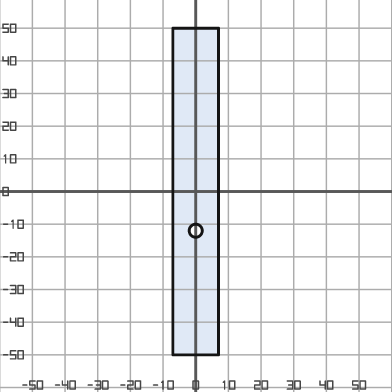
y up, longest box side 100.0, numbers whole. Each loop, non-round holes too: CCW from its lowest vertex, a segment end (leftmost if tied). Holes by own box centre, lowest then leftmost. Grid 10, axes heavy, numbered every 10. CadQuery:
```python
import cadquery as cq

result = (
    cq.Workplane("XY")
    .moveTo(-7.0, -50.0)
    .lineTo(7.0, -50.0)
    .lineTo(7.0, 50.0)
    .lineTo(-7.0, 50.0)
    .close()
    .moveTo(0.0, -12.0)
    .circle(2.0)
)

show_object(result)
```